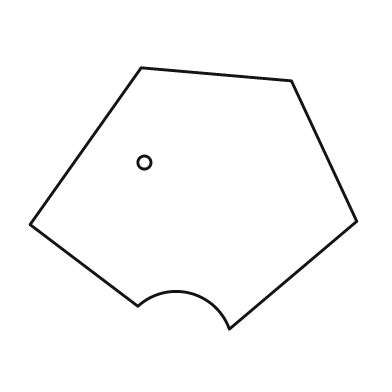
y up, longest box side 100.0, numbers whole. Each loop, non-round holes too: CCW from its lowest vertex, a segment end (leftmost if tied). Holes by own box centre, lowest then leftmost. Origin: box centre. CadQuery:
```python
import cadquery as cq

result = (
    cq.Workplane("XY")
    .moveTo(11.0, -40.0)
    .lineTo(50.0, -7.0)
    .lineTo(30.0, 36.0)
    .lineTo(-16.0, 40.0)
    .lineTo(-50.0, -8.0)
    .lineTo(-17.0, -33.0)
    .threePointArc((-1.0, -29.0), (11.0, -40.0))
    .close()
    .moveTo(-15.0, 11.0)
    .circle(2.0)
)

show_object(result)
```